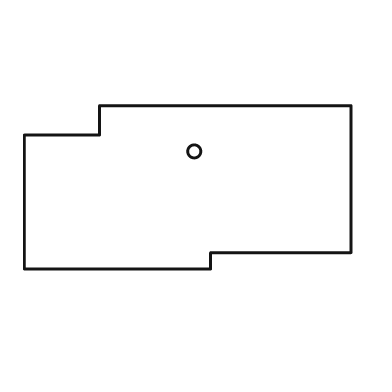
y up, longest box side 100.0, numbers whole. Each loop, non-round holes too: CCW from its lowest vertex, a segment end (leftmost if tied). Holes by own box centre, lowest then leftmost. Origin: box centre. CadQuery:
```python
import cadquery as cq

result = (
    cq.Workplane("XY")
    .moveTo(-50.0, -25.0)
    .lineTo(7.0, -25.0)
    .lineTo(7.0, -20.0)
    .lineTo(50.0, -20.0)
    .lineTo(50.0, 25.0)
    .lineTo(-27.0, 25.0)
    .lineTo(-27.0, 16.0)
    .lineTo(-50.0, 16.0)
    .close()
    .moveTo(2.0, 11.0)
    .circle(2.0)
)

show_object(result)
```